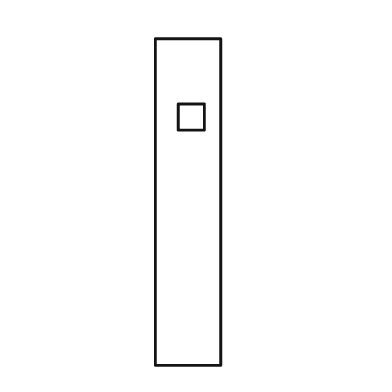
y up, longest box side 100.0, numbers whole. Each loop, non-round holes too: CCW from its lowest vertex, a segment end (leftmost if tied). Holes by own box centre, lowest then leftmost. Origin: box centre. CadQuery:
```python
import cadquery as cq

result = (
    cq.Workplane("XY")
    .moveTo(-10.0, -50.0)
    .lineTo(10.0, -50.0)
    .lineTo(10.0, 50.0)
    .lineTo(-10.0, 50.0)
    .close()
    .moveTo(-3.0, 22.0)
    .lineTo(5.0, 22.0)
    .lineTo(5.0, 30.0)
    .lineTo(-3.0, 30.0)
    .close()
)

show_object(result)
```